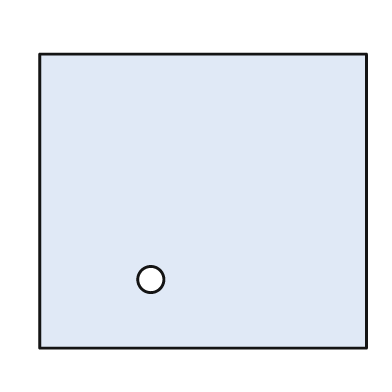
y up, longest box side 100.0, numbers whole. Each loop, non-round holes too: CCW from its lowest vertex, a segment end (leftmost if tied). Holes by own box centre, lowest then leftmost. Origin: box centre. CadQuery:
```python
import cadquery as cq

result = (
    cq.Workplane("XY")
    .moveTo(-50.0, -45.0)
    .lineTo(50.0, -45.0)
    .lineTo(50.0, 45.0)
    .lineTo(-50.0, 45.0)
    .close()
    .moveTo(-16.0, -24.0)
    .circle(4.0)
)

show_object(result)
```